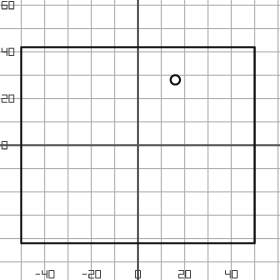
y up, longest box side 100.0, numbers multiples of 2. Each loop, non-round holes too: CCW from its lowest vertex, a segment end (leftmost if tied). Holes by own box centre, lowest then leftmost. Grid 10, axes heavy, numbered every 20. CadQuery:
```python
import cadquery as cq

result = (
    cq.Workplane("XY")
    .moveTo(-50.0, -42.0)
    .lineTo(50.0, -42.0)
    .lineTo(50.0, 42.0)
    .lineTo(-50.0, 42.0)
    .close()
    .moveTo(16.0, 28.0)
    .circle(2.0)
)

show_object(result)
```